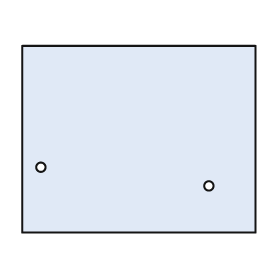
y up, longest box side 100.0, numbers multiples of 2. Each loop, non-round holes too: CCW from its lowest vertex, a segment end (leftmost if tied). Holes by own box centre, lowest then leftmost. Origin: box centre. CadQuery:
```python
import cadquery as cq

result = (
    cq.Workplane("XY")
    .moveTo(-50.0, -40.0)
    .lineTo(50.0, -40.0)
    .lineTo(50.0, 40.0)
    .lineTo(-50.0, 40.0)
    .close()
    .moveTo(30.0, -20.0)
    .circle(2.0)
    .moveTo(-42.0, -12.0)
    .circle(2.0)
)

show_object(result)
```